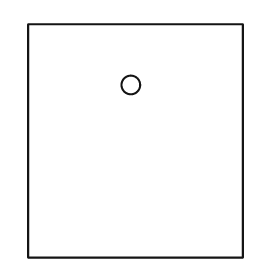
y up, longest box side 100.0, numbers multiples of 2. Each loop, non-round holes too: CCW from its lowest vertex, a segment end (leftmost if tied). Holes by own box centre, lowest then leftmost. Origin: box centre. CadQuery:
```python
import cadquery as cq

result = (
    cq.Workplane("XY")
    .moveTo(-46.0, -50.0)
    .lineTo(46.0, -50.0)
    .lineTo(46.0, 50.0)
    .lineTo(-46.0, 50.0)
    .close()
    .moveTo(-2.0, 24.0)
    .circle(4.0)
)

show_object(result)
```